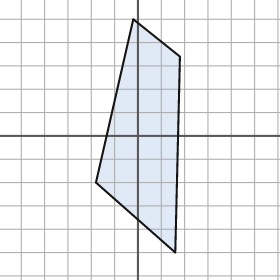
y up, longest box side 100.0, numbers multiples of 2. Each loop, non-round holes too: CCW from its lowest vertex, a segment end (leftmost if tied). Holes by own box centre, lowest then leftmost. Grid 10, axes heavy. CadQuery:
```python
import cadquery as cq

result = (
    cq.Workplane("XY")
    .moveTo(16.0, -50.0)
    .lineTo(18.0, 34.0)
    .lineTo(-2.0, 50.0)
    .lineTo(-18.0, -20.0)
    .close()
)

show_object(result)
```